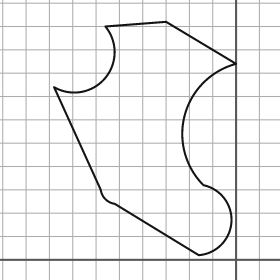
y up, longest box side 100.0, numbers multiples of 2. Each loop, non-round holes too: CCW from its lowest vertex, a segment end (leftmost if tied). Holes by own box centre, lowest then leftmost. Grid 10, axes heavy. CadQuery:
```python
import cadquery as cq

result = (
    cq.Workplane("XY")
    .moveTo(-16.0, 2.0)
    .threePointArc((-2.0, 16.0), (-14.0, 32.0))
    .threePointArc((-22.0, 62.0), (0.0, 84.0))
    .lineTo(-30.0, 102.0)
    .lineTo(-56.0, 100.0)
    .threePointArc((-56.0, 78.0), (-78.0, 74.0))
    .lineTo(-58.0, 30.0)
    .threePointArc((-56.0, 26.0), (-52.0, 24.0))
    .close()
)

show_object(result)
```